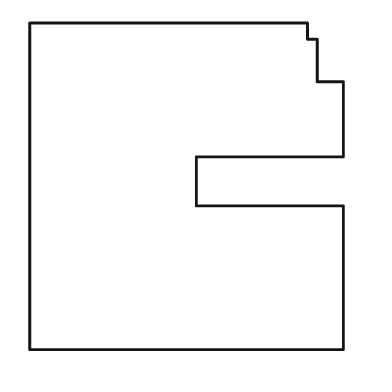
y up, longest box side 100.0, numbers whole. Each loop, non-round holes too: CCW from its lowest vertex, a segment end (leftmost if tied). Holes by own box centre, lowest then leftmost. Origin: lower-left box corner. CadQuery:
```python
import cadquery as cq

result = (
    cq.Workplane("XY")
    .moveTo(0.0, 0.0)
    .lineTo(96.0, 0.0)
    .lineTo(96.0, 44.0)
    .lineTo(51.0, 44.0)
    .lineTo(51.0, 59.0)
    .lineTo(96.0, 59.0)
    .lineTo(96.0, 82.0)
    .lineTo(88.0, 82.0)
    .lineTo(88.0, 95.0)
    .lineTo(85.0, 95.0)
    .lineTo(85.0, 100.0)
    .lineTo(0.0, 100.0)
    .close()
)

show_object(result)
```